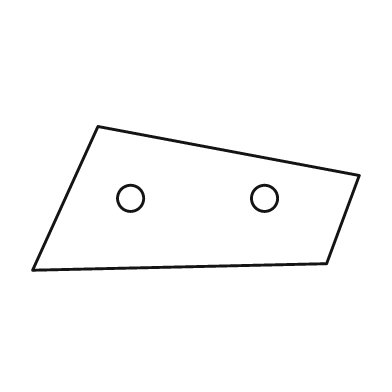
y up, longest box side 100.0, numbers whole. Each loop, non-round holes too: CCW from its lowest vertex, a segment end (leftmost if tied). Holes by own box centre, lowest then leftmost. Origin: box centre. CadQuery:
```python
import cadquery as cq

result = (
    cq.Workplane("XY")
    .moveTo(-50.0, -22.0)
    .lineTo(40.0, -20.0)
    .lineTo(50.0, 7.0)
    .lineTo(-30.0, 22.0)
    .close()
    .moveTo(-20.0, 0.0)
    .circle(4.0)
    .moveTo(21.0, 0.0)
    .circle(4.0)
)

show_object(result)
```